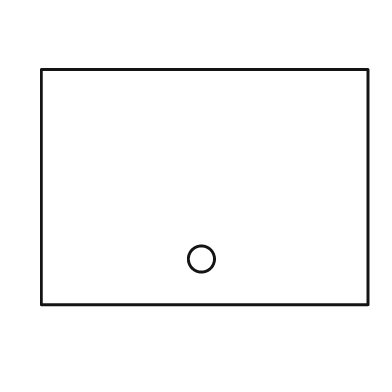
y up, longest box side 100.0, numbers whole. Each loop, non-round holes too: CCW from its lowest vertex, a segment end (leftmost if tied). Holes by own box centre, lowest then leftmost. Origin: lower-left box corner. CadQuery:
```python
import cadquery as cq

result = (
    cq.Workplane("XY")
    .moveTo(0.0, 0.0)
    .lineTo(100.0, 0.0)
    .lineTo(100.0, 72.0)
    .lineTo(0.0, 72.0)
    .close()
    .moveTo(49.0, 14.0)
    .circle(4.0)
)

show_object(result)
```